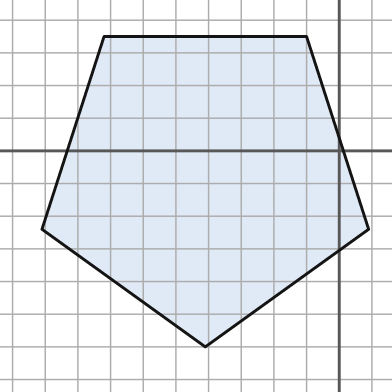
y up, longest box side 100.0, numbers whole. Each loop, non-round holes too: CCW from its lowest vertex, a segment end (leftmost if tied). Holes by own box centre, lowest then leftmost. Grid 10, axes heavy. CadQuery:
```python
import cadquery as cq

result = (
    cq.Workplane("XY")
    .moveTo(-41.0, -60.0)
    .lineTo(9.0, -24.0)
    .lineTo(-10.0, 35.0)
    .lineTo(-72.0, 35.0)
    .lineTo(-91.0, -24.0)
    .close()
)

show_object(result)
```